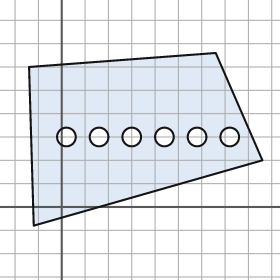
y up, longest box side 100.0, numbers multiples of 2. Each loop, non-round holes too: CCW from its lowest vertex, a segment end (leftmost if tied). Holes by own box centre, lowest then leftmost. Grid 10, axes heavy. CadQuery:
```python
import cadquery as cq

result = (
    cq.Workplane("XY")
    .moveTo(-12.0, -8.0)
    .lineTo(86.0, 20.0)
    .lineTo(66.0, 66.0)
    .lineTo(-14.0, 60.0)
    .close()
    .moveTo(2.0, 30.0)
    .circle(4.0)
    .moveTo(16.0, 30.0)
    .circle(4.0)
    .moveTo(30.0, 30.0)
    .circle(4.0)
    .moveTo(44.0, 30.0)
    .circle(4.0)
    .moveTo(58.0, 30.0)
    .circle(4.0)
    .moveTo(72.0, 30.0)
    .circle(4.0)
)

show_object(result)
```